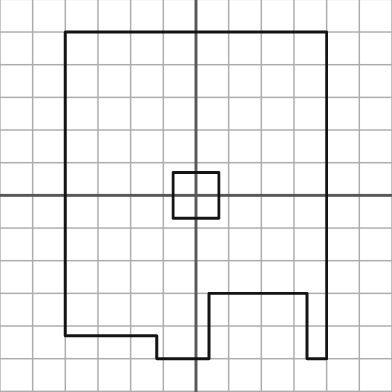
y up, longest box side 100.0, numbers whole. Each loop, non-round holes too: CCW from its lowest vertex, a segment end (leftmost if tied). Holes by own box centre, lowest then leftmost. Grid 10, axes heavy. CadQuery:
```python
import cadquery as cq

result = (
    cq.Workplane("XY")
    .moveTo(-12.0, -50.0)
    .lineTo(4.0, -50.0)
    .lineTo(4.0, -30.0)
    .lineTo(34.0, -30.0)
    .lineTo(34.0, -50.0)
    .lineTo(40.0, -50.0)
    .lineTo(40.0, 50.0)
    .lineTo(-40.0, 50.0)
    .lineTo(-40.0, -43.0)
    .lineTo(-12.0, -43.0)
    .close()
    .moveTo(-7.0, -7.0)
    .lineTo(7.0, -7.0)
    .lineTo(7.0, 7.0)
    .lineTo(-7.0, 7.0)
    .close()
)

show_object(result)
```